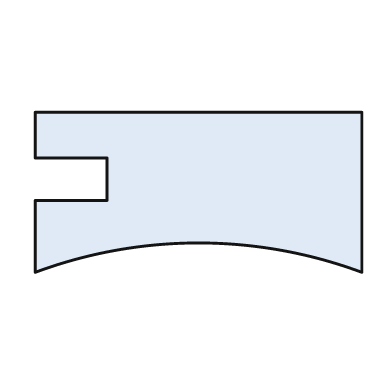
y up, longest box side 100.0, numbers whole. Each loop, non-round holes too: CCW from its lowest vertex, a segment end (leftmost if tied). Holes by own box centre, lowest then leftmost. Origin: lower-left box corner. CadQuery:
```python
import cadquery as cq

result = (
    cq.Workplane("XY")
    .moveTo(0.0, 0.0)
    .threePointArc((50.0, 9.0), (100.0, 0.0))
    .lineTo(100.0, 49.0)
    .lineTo(0.0, 49.0)
    .lineTo(0.0, 35.0)
    .lineTo(22.0, 35.0)
    .lineTo(22.0, 22.0)
    .lineTo(0.0, 22.0)
    .close()
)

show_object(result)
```